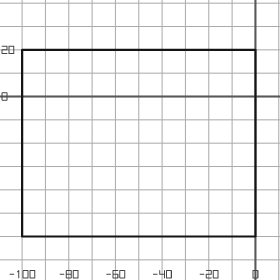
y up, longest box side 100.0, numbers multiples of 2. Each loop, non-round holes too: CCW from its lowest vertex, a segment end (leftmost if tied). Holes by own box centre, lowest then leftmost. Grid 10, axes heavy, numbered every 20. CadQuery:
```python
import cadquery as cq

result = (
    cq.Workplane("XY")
    .moveTo(-100.0, -60.0)
    .lineTo(0.0, -60.0)
    .lineTo(0.0, 20.0)
    .lineTo(-100.0, 20.0)
    .close()
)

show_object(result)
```